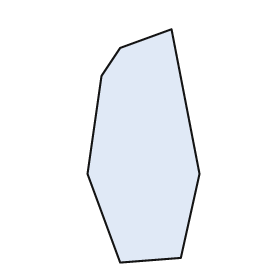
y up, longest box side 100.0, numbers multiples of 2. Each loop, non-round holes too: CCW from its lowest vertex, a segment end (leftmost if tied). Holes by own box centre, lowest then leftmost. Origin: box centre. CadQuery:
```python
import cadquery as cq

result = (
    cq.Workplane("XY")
    .moveTo(-10.0, -50.0)
    .lineTo(16.0, -48.0)
    .lineTo(24.0, -12.0)
    .lineTo(12.0, 50.0)
    .lineTo(-10.0, 42.0)
    .lineTo(-18.0, 30.0)
    .lineTo(-24.0, -12.0)
    .close()
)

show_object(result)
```